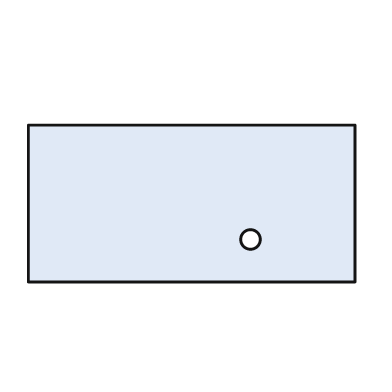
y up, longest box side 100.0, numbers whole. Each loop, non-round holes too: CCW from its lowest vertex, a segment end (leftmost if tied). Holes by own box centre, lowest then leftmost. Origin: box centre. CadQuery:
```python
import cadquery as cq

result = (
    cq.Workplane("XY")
    .moveTo(-50.0, -24.0)
    .lineTo(50.0, -24.0)
    .lineTo(50.0, 24.0)
    .lineTo(-50.0, 24.0)
    .close()
    .moveTo(18.0, -11.0)
    .circle(3.0)
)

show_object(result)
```